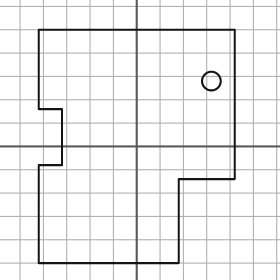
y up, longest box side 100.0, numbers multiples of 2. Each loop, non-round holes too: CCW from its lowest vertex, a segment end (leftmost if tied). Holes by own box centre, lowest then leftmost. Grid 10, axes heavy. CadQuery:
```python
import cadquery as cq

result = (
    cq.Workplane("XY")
    .moveTo(-42.0, -50.0)
    .lineTo(18.0, -50.0)
    .lineTo(18.0, -14.0)
    .lineTo(42.0, -14.0)
    .lineTo(42.0, 50.0)
    .lineTo(-42.0, 50.0)
    .lineTo(-42.0, 16.0)
    .lineTo(-32.0, 16.0)
    .lineTo(-32.0, -8.0)
    .lineTo(-42.0, -8.0)
    .close()
    .moveTo(32.0, 28.0)
    .circle(4.0)
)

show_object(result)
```